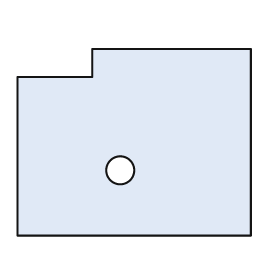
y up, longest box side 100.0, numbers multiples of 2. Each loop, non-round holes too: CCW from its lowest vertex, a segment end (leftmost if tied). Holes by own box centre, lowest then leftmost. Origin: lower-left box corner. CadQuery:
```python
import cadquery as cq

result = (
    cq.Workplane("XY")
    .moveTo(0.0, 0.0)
    .lineTo(100.0, 0.0)
    .lineTo(100.0, 80.0)
    .lineTo(32.0, 80.0)
    .lineTo(32.0, 68.0)
    .lineTo(0.0, 68.0)
    .close()
    .moveTo(44.0, 28.0)
    .circle(6.0)
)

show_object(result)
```